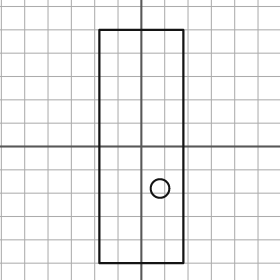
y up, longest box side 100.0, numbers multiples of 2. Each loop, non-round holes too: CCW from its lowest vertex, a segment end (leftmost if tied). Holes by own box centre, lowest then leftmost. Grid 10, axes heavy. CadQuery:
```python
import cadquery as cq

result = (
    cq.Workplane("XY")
    .moveTo(-18.0, -50.0)
    .lineTo(18.0, -50.0)
    .lineTo(18.0, 50.0)
    .lineTo(-18.0, 50.0)
    .close()
    .moveTo(8.0, -18.0)
    .circle(4.0)
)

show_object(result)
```